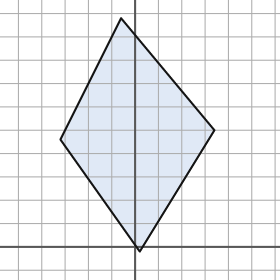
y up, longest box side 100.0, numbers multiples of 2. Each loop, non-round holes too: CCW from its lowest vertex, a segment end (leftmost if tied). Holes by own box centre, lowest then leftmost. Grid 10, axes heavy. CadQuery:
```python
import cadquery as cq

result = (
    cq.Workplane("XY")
    .moveTo(2.0, -2.0)
    .lineTo(34.0, 50.0)
    .lineTo(-6.0, 98.0)
    .lineTo(-32.0, 46.0)
    .close()
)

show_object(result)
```